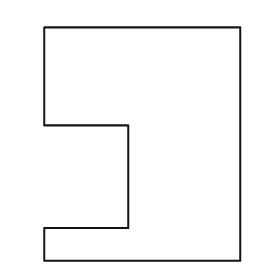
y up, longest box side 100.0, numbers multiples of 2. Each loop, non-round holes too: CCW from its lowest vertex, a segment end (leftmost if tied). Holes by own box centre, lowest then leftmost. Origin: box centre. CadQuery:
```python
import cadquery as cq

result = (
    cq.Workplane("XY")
    .moveTo(-42.0, -50.0)
    .lineTo(42.0, -50.0)
    .lineTo(42.0, 50.0)
    .lineTo(-42.0, 50.0)
    .lineTo(-42.0, 8.0)
    .lineTo(-6.0, 8.0)
    .lineTo(-6.0, -36.0)
    .lineTo(-42.0, -36.0)
    .close()
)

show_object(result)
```